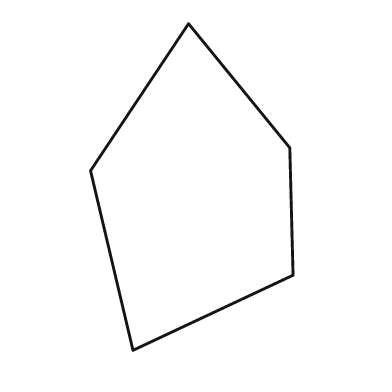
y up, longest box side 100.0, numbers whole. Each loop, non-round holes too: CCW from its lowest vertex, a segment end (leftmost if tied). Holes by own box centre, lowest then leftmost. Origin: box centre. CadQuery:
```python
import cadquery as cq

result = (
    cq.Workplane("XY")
    .moveTo(-18.0, -50.0)
    .lineTo(31.0, -27.0)
    .lineTo(30.0, 12.0)
    .lineTo(-1.0, 50.0)
    .lineTo(-31.0, 5.0)
    .close()
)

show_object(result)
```